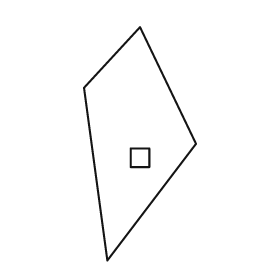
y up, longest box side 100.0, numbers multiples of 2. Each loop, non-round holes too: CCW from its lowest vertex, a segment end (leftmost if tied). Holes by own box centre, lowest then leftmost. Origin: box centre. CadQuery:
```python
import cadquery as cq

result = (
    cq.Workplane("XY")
    .moveTo(-14.0, -50.0)
    .lineTo(24.0, 0.0)
    .lineTo(0.0, 50.0)
    .lineTo(-24.0, 24.0)
    .close()
    .moveTo(-4.0, -10.0)
    .lineTo(4.0, -10.0)
    .lineTo(4.0, -2.0)
    .lineTo(-4.0, -2.0)
    .close()
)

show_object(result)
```